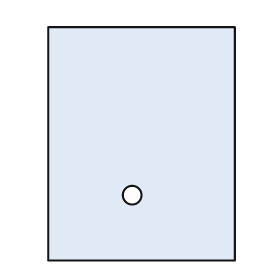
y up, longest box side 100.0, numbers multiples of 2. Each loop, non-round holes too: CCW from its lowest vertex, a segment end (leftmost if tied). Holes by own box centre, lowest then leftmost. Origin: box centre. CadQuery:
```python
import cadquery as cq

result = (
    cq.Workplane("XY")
    .moveTo(-40.0, -50.0)
    .lineTo(40.0, -50.0)
    .lineTo(40.0, 50.0)
    .lineTo(-40.0, 50.0)
    .close()
    .moveTo(-4.0, -22.0)
    .circle(4.0)
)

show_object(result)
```